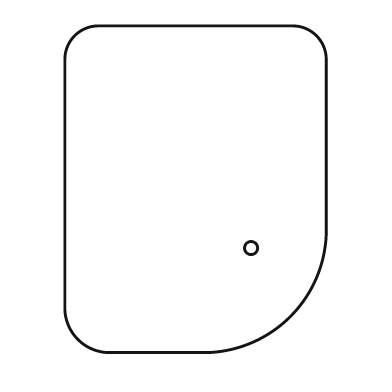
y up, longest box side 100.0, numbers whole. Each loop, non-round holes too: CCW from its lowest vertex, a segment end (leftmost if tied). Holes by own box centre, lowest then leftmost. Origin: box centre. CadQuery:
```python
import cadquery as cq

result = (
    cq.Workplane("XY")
    .moveTo(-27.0, -50.0)
    .lineTo(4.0, -50.0)
    .threePointArc((29.0, -39.0), (40.0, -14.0))
    .lineTo(40.0, 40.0)
    .threePointArc((37.0, 47.0), (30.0, 50.0))
    .lineTo(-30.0, 50.0)
    .threePointArc((-37.0, 47.0), (-40.0, 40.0))
    .lineTo(-40.0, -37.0)
    .threePointArc((-36.0, -46.0), (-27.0, -50.0))
    .close()
    .moveTo(17.0, -18.0)
    .circle(2.0)
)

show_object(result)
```